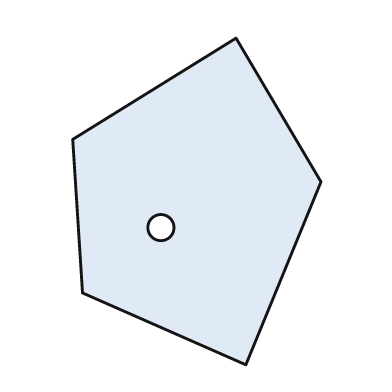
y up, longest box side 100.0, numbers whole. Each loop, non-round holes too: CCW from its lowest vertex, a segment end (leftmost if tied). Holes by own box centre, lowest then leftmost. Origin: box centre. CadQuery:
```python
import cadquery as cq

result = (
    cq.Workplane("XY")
    .moveTo(15.0, -50.0)
    .lineTo(38.0, 6.0)
    .lineTo(12.0, 50.0)
    .lineTo(-38.0, 19.0)
    .lineTo(-35.0, -28.0)
    .close()
    .moveTo(-11.0, -8.0)
    .circle(4.0)
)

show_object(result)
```